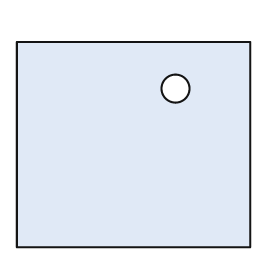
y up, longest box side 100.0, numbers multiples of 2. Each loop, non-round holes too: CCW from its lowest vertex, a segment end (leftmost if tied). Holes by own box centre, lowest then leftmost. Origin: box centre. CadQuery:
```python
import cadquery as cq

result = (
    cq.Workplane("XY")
    .moveTo(-50.0, -44.0)
    .lineTo(50.0, -44.0)
    .lineTo(50.0, 44.0)
    .lineTo(-50.0, 44.0)
    .close()
    .moveTo(18.0, 24.0)
    .circle(6.0)
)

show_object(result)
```